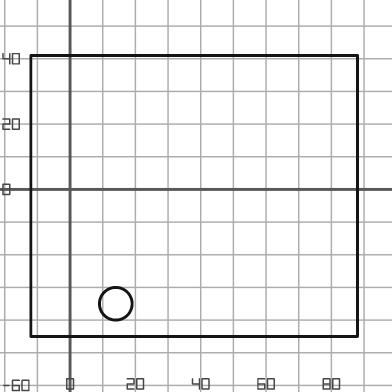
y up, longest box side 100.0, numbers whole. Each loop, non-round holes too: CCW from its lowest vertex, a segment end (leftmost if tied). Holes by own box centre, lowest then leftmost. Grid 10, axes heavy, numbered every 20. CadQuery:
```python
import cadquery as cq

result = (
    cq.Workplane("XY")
    .moveTo(-12.0, -45.0)
    .lineTo(88.0, -45.0)
    .lineTo(88.0, 41.0)
    .lineTo(-12.0, 41.0)
    .close()
    .moveTo(14.0, -35.0)
    .circle(5.0)
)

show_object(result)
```